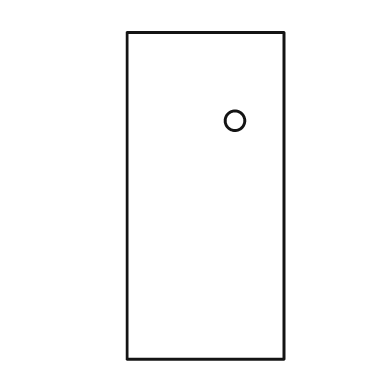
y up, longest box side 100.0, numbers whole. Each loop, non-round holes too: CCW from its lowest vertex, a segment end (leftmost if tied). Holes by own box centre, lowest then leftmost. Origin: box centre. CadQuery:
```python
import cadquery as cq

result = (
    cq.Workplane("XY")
    .moveTo(-24.0, -50.0)
    .lineTo(24.0, -50.0)
    .lineTo(24.0, 50.0)
    .lineTo(-24.0, 50.0)
    .close()
    .moveTo(9.0, 23.0)
    .circle(3.0)
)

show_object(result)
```